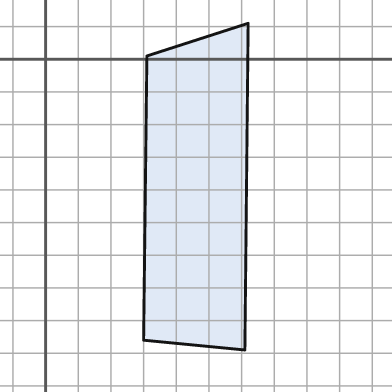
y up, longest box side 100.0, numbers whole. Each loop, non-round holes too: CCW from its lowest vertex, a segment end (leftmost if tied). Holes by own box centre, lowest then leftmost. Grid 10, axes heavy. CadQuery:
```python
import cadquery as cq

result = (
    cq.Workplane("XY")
    .moveTo(61.0, -89.0)
    .lineTo(62.0, 11.0)
    .lineTo(31.0, 1.0)
    .lineTo(30.0, -86.0)
    .close()
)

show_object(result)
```